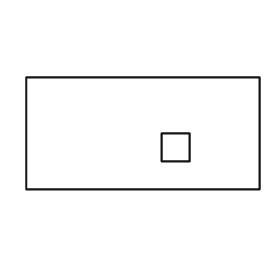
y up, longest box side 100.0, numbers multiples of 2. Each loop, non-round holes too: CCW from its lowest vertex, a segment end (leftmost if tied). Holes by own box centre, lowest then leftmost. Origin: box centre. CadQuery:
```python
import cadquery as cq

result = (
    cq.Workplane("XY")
    .moveTo(-50.0, -24.0)
    .lineTo(50.0, -24.0)
    .lineTo(50.0, 24.0)
    .lineTo(-50.0, 24.0)
    .close()
    .moveTo(8.0, -12.0)
    .lineTo(20.0, -12.0)
    .lineTo(20.0, 0.0)
    .lineTo(8.0, 0.0)
    .close()
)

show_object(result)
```